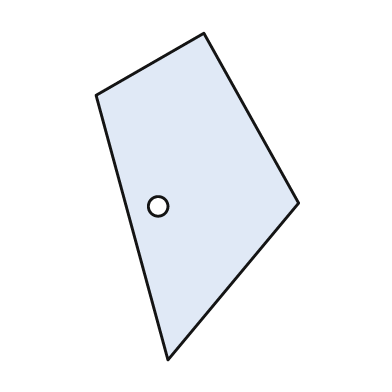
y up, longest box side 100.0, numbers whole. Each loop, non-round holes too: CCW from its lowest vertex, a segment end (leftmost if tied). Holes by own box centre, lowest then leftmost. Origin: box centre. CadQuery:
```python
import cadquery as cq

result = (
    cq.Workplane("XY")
    .moveTo(-9.0, -50.0)
    .lineTo(31.0, -2.0)
    .lineTo(2.0, 50.0)
    .lineTo(-31.0, 31.0)
    .close()
    .moveTo(-12.0, -3.0)
    .circle(3.0)
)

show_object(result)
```